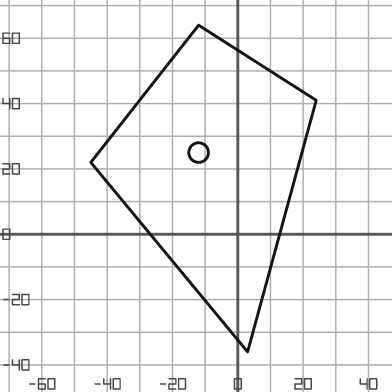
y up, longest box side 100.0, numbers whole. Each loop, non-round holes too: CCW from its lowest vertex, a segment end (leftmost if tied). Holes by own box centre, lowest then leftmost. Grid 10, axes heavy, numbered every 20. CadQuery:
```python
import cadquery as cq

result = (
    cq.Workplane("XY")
    .moveTo(3.0, -36.0)
    .lineTo(24.0, 41.0)
    .lineTo(-12.0, 64.0)
    .lineTo(-45.0, 22.0)
    .close()
    .moveTo(-12.0, 25.0)
    .circle(3.0)
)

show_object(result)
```